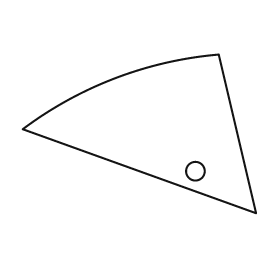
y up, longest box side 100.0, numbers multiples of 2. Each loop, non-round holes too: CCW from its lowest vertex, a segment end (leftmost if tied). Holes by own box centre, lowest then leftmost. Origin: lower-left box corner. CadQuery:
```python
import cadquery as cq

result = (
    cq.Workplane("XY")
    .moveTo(100.0, 0.0)
    .lineTo(84.0, 68.0)
    .threePointArc((40.0, 58.0), (0.0, 36.0))
    .close()
    .moveTo(74.0, 18.0)
    .circle(4.0)
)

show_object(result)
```